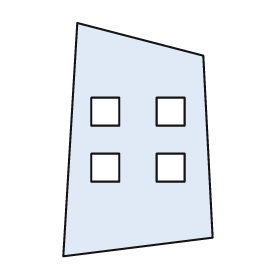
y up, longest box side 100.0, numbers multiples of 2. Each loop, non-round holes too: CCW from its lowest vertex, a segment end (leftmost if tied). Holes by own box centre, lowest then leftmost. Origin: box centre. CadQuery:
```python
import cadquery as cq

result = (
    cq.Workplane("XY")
    .moveTo(-32.0, -50.0)
    .lineTo(32.0, -42.0)
    .lineTo(28.0, 36.0)
    .lineTo(-26.0, 50.0)
    .close()
    .moveTo(-20.0, -18.0)
    .lineTo(-8.0, -18.0)
    .lineTo(-8.0, -6.0)
    .lineTo(-20.0, -6.0)
    .close()
    .moveTo(8.0, -18.0)
    .lineTo(20.0, -18.0)
    .lineTo(20.0, -6.0)
    .lineTo(8.0, -6.0)
    .close()
    .moveTo(-20.0, 6.0)
    .lineTo(-8.0, 6.0)
    .lineTo(-8.0, 18.0)
    .lineTo(-20.0, 18.0)
    .close()
    .moveTo(8.0, 6.0)
    .lineTo(20.0, 6.0)
    .lineTo(20.0, 18.0)
    .lineTo(8.0, 18.0)
    .close()
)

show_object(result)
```